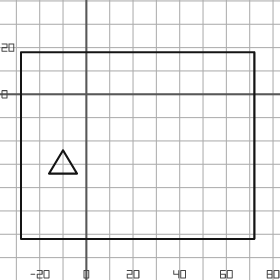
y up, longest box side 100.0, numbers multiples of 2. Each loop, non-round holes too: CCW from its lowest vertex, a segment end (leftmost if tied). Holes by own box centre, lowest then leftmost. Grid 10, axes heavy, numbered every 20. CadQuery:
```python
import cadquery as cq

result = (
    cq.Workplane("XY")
    .moveTo(-28.0, -62.0)
    .lineTo(72.0, -62.0)
    .lineTo(72.0, 18.0)
    .lineTo(-28.0, 18.0)
    .close()
    .moveTo(-16.0, -34.0)
    .lineTo(-4.0, -34.0)
    .lineTo(-10.0, -24.0)
    .close()
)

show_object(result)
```